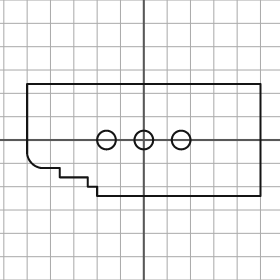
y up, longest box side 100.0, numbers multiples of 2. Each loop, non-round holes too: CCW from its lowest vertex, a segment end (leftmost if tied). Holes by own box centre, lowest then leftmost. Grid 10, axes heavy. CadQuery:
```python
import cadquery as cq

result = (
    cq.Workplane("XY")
    .moveTo(-20.0, -24.0)
    .lineTo(50.0, -24.0)
    .lineTo(50.0, 24.0)
    .lineTo(-50.0, 24.0)
    .lineTo(-50.0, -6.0)
    .threePointArc((-48.0, -10.0), (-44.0, -12.0))
    .lineTo(-36.0, -12.0)
    .lineTo(-36.0, -16.0)
    .lineTo(-24.0, -16.0)
    .lineTo(-24.0, -20.0)
    .lineTo(-20.0, -20.0)
    .close()
    .moveTo(-16.0, 0.0)
    .circle(4.0)
    .moveTo(0.0, 0.0)
    .circle(4.0)
    .moveTo(16.0, 0.0)
    .circle(4.0)
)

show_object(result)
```